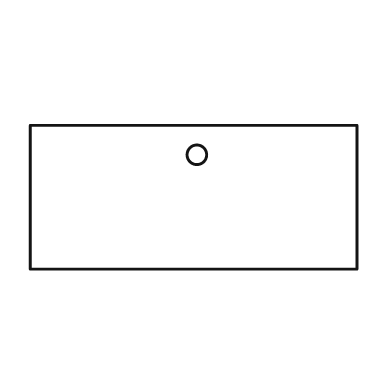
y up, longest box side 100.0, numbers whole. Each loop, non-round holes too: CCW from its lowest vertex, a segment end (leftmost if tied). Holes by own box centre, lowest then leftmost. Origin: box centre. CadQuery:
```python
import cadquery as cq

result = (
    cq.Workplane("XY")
    .moveTo(-50.0, -22.0)
    .lineTo(50.0, -22.0)
    .lineTo(50.0, 22.0)
    .lineTo(-50.0, 22.0)
    .close()
    .moveTo(1.0, 13.0)
    .circle(3.0)
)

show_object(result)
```